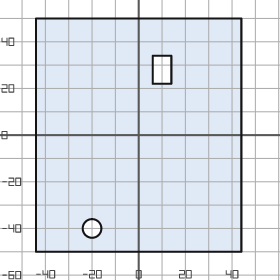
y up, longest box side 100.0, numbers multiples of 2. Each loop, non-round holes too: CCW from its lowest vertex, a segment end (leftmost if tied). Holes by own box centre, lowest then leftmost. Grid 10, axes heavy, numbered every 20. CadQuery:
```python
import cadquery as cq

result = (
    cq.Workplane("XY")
    .moveTo(-44.0, -50.0)
    .lineTo(44.0, -50.0)
    .lineTo(44.0, 50.0)
    .lineTo(-44.0, 50.0)
    .close()
    .moveTo(-20.0, -40.0)
    .circle(4.0)
    .moveTo(6.0, 22.0)
    .lineTo(14.0, 22.0)
    .lineTo(14.0, 34.0)
    .lineTo(6.0, 34.0)
    .close()
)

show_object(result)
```